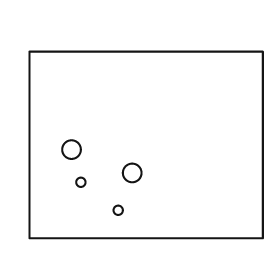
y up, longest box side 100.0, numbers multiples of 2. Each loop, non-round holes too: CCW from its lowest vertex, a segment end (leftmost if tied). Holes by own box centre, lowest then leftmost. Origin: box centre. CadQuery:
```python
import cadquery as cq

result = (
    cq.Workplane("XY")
    .moveTo(-50.0, -40.0)
    .lineTo(50.0, -40.0)
    .lineTo(50.0, 40.0)
    .lineTo(-50.0, 40.0)
    .close()
    .moveTo(-12.0, -28.0)
    .circle(2.0)
    .moveTo(-28.0, -16.0)
    .circle(2.0)
    .moveTo(-6.0, -12.0)
    .circle(4.0)
    .moveTo(-32.0, -2.0)
    .circle(4.0)
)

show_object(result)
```